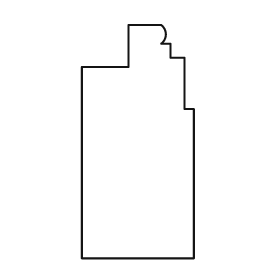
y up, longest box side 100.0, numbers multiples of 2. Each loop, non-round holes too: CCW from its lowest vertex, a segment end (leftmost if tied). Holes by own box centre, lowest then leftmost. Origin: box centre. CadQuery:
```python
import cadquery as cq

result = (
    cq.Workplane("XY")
    .moveTo(-24.0, -50.0)
    .lineTo(24.0, -50.0)
    .lineTo(24.0, 14.0)
    .lineTo(20.0, 14.0)
    .lineTo(20.0, 36.0)
    .lineTo(14.0, 36.0)
    .lineTo(14.0, 42.0)
    .lineTo(10.0, 42.0)
    .threePointArc((12.0, 46.0), (10.0, 50.0))
    .lineTo(-4.0, 50.0)
    .lineTo(-4.0, 32.0)
    .lineTo(-24.0, 32.0)
    .close()
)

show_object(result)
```